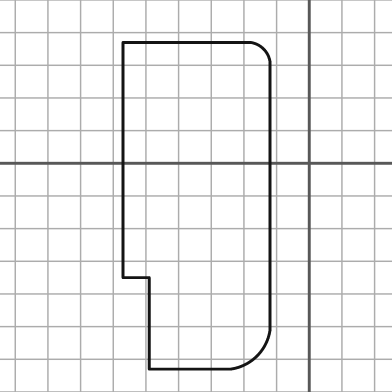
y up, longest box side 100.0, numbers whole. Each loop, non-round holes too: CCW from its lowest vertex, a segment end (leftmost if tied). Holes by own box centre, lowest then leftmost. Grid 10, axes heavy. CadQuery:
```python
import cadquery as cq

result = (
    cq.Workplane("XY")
    .moveTo(-49.0, -63.0)
    .lineTo(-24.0, -63.0)
    .threePointArc((-16.0, -59.0), (-12.0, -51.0))
    .lineTo(-12.0, 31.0)
    .threePointArc((-14.0, 35.0), (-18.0, 37.0))
    .lineTo(-57.0, 37.0)
    .lineTo(-57.0, -35.0)
    .lineTo(-49.0, -35.0)
    .close()
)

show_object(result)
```